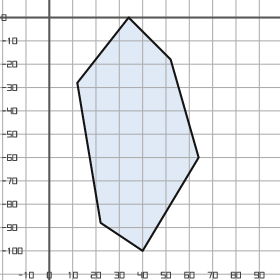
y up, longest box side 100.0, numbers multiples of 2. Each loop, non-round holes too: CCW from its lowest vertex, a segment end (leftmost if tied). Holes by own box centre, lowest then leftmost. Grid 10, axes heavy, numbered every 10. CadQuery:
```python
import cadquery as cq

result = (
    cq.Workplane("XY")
    .moveTo(40.0, -100.0)
    .lineTo(64.0, -60.0)
    .lineTo(52.0, -18.0)
    .lineTo(34.0, 0.0)
    .lineTo(12.0, -28.0)
    .lineTo(22.0, -88.0)
    .close()
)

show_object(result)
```